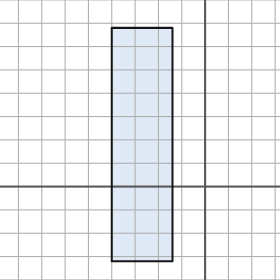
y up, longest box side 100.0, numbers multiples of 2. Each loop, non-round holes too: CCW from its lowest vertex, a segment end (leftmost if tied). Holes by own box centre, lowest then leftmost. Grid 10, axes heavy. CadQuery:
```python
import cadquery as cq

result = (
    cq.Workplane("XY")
    .moveTo(-40.0, -32.0)
    .lineTo(-14.0, -32.0)
    .lineTo(-14.0, 68.0)
    .lineTo(-40.0, 68.0)
    .close()
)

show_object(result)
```